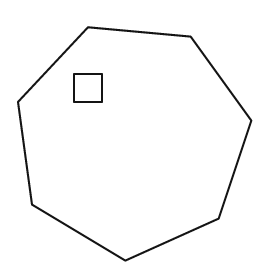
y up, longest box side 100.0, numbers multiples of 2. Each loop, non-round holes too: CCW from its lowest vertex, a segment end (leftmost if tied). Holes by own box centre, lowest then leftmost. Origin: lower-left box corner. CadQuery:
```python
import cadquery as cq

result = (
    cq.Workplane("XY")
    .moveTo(46.0, 0.0)
    .lineTo(86.0, 18.0)
    .lineTo(100.0, 60.0)
    .lineTo(74.0, 96.0)
    .lineTo(30.0, 100.0)
    .lineTo(0.0, 68.0)
    .lineTo(6.0, 24.0)
    .close()
    .moveTo(24.0, 68.0)
    .lineTo(36.0, 68.0)
    .lineTo(36.0, 80.0)
    .lineTo(24.0, 80.0)
    .close()
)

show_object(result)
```